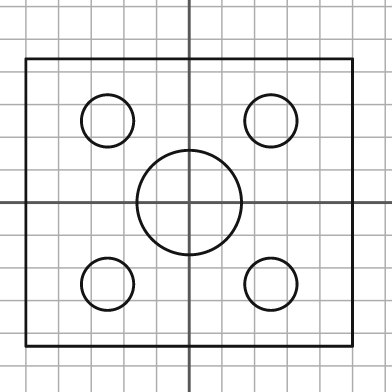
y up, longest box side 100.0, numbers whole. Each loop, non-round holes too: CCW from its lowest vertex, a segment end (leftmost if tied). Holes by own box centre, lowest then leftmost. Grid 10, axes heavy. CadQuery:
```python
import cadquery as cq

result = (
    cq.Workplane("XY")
    .moveTo(-50.0, -44.0)
    .lineTo(50.0, -44.0)
    .lineTo(50.0, 44.0)
    .lineTo(-50.0, 44.0)
    .close()
    .moveTo(-25.0, -25.0)
    .circle(8.0)
    .moveTo(25.0, -25.0)
    .circle(8.0)
    .moveTo(0.0, 0.0)
    .circle(16.0)
    .moveTo(-25.0, 25.0)
    .circle(8.0)
    .moveTo(25.0, 25.0)
    .circle(8.0)
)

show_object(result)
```